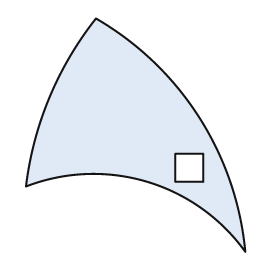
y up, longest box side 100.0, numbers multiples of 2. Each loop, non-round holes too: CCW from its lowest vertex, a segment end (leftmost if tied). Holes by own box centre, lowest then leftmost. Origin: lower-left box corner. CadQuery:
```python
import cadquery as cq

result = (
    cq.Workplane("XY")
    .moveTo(94.0, 0.0)
    .threePointArc((74.0, 58.0), (30.0, 100.0))
    .threePointArc((10.0, 66.0), (0.0, 28.0))
    .threePointArc((52.0, 30.0), (94.0, 0.0))
    .close()
    .moveTo(64.0, 30.0)
    .lineTo(76.0, 30.0)
    .lineTo(76.0, 42.0)
    .lineTo(64.0, 42.0)
    .close()
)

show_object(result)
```